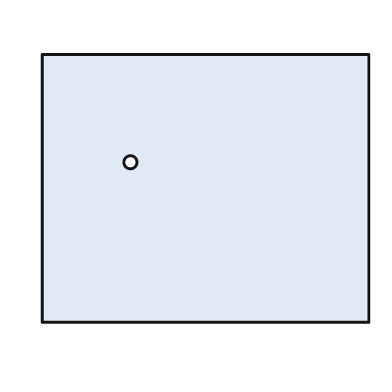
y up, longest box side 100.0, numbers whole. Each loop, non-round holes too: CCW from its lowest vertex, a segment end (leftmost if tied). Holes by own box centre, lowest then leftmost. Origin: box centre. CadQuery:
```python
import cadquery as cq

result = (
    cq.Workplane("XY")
    .moveTo(-50.0, -41.0)
    .lineTo(50.0, -41.0)
    .lineTo(50.0, 41.0)
    .lineTo(-50.0, 41.0)
    .close()
    .moveTo(-23.0, 8.0)
    .circle(2.0)
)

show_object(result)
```